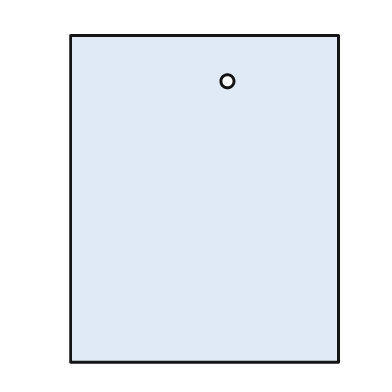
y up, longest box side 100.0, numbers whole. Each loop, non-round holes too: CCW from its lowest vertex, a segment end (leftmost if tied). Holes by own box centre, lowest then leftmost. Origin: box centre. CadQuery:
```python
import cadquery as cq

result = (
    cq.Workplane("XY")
    .moveTo(-41.0, -50.0)
    .lineTo(41.0, -50.0)
    .lineTo(41.0, 50.0)
    .lineTo(-41.0, 50.0)
    .close()
    .moveTo(7.0, 36.0)
    .circle(2.0)
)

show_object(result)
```